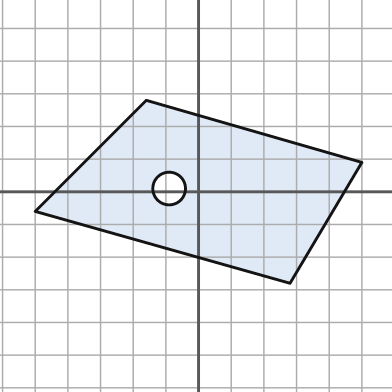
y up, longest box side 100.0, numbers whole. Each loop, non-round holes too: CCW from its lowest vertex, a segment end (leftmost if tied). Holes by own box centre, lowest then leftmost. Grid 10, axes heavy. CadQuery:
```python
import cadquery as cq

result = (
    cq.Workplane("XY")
    .moveTo(28.0, -28.0)
    .lineTo(50.0, 9.0)
    .lineTo(-16.0, 28.0)
    .lineTo(-50.0, -6.0)
    .close()
    .moveTo(-9.0, 1.0)
    .circle(5.0)
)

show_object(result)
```